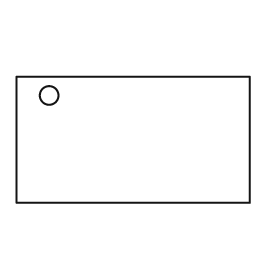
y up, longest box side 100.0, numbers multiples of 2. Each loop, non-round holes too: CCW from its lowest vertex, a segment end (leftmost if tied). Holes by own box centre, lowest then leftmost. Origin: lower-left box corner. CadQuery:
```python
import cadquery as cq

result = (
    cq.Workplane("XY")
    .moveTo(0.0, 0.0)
    .lineTo(100.0, 0.0)
    .lineTo(100.0, 54.0)
    .lineTo(0.0, 54.0)
    .close()
    .moveTo(14.0, 46.0)
    .circle(4.0)
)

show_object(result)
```